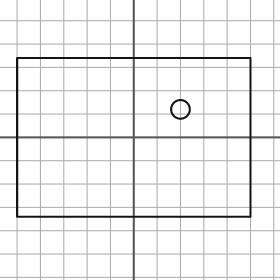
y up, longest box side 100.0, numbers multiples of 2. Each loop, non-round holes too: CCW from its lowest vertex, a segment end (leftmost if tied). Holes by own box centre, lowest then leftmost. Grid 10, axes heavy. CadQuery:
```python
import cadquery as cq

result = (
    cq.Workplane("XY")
    .moveTo(-50.0, -34.0)
    .lineTo(50.0, -34.0)
    .lineTo(50.0, 34.0)
    .lineTo(-50.0, 34.0)
    .close()
    .moveTo(20.0, 12.0)
    .circle(4.0)
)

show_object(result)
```